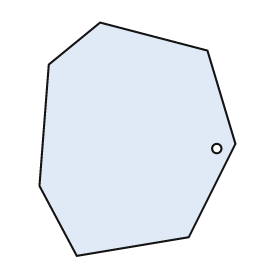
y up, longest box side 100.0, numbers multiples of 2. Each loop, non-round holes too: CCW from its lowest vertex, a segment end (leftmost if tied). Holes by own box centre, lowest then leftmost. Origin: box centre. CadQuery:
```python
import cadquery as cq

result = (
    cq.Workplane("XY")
    .moveTo(-26.0, -50.0)
    .lineTo(22.0, -42.0)
    .lineTo(42.0, -2.0)
    .lineTo(30.0, 38.0)
    .lineTo(-16.0, 50.0)
    .lineTo(-38.0, 32.0)
    .lineTo(-42.0, -20.0)
    .close()
    .moveTo(34.0, -4.0)
    .circle(2.0)
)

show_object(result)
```